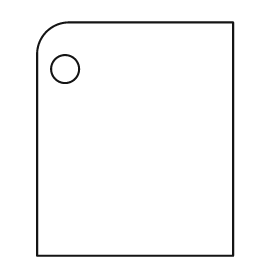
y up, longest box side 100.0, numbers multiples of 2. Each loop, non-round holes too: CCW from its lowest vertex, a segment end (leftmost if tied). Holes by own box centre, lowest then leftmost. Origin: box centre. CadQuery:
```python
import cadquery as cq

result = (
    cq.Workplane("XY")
    .moveTo(-42.0, -50.0)
    .lineTo(42.0, -50.0)
    .lineTo(42.0, 50.0)
    .lineTo(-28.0, 50.0)
    .threePointArc((-38.0, 46.0), (-42.0, 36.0))
    .close()
    .moveTo(-30.0, 30.0)
    .circle(6.0)
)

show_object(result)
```